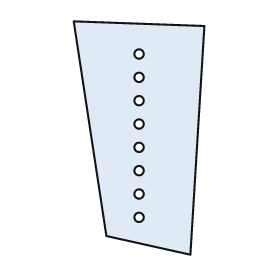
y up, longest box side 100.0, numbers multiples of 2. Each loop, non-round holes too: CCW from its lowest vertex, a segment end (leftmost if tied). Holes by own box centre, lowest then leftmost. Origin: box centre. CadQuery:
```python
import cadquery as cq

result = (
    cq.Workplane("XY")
    .moveTo(22.0, -50.0)
    .lineTo(28.0, 48.0)
    .lineTo(-28.0, 50.0)
    .lineTo(-14.0, -42.0)
    .close()
    .moveTo(0.0, -34.0)
    .circle(2.0)
    .moveTo(0.0, -24.0)
    .circle(2.0)
    .moveTo(0.0, -14.0)
    .circle(2.0)
    .moveTo(0.0, -4.0)
    .circle(2.0)
    .moveTo(0.0, 6.0)
    .circle(2.0)
    .moveTo(0.0, 16.0)
    .circle(2.0)
    .moveTo(0.0, 26.0)
    .circle(2.0)
    .moveTo(0.0, 36.0)
    .circle(2.0)
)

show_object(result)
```